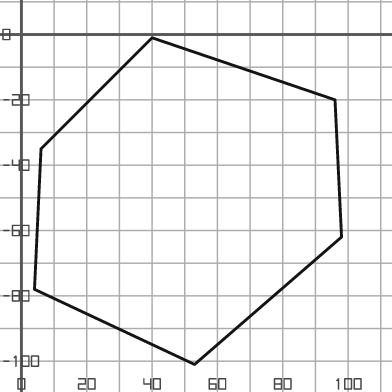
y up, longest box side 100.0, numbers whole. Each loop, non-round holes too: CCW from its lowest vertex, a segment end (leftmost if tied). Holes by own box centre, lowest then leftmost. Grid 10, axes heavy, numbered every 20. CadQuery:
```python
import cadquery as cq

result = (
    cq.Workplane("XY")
    .moveTo(53.0, -101.0)
    .lineTo(98.0, -62.0)
    .lineTo(96.0, -20.0)
    .lineTo(40.0, -1.0)
    .lineTo(6.0, -35.0)
    .lineTo(4.0, -78.0)
    .close()
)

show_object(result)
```